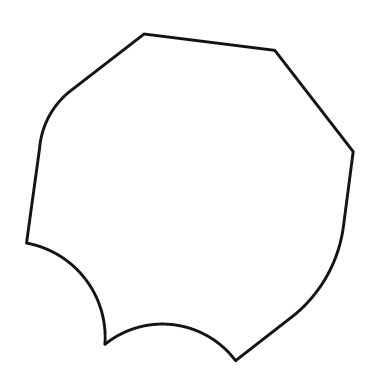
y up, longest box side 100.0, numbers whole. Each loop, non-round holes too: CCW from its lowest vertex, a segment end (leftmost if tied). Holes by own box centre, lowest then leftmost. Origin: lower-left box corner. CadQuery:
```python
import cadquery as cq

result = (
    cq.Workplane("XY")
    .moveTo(64.0, 0.0)
    .lineTo(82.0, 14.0)
    .threePointArc((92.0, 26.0), (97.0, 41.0))
    .lineTo(100.0, 64.0)
    .lineTo(76.0, 95.0)
    .lineTo(36.0, 100.0)
    .lineTo(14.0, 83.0)
    .threePointArc((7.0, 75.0), (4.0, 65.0))
    .lineTo(0.0, 36.0)
    .threePointArc((18.0, 25.0), (24.0, 5.0))
    .threePointArc((45.0, 11.0), (64.0, 0.0))
    .close()
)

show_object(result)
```